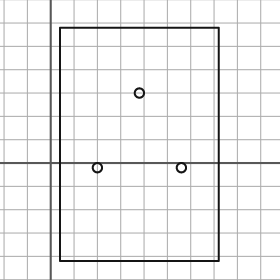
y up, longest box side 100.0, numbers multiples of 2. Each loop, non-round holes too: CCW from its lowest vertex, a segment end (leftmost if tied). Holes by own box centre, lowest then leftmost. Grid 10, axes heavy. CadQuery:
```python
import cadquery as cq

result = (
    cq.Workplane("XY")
    .moveTo(4.0, -42.0)
    .lineTo(72.0, -42.0)
    .lineTo(72.0, 58.0)
    .lineTo(4.0, 58.0)
    .close()
    .moveTo(20.0, -2.0)
    .circle(2.0)
    .moveTo(56.0, -2.0)
    .circle(2.0)
    .moveTo(38.0, 30.0)
    .circle(2.0)
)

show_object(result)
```